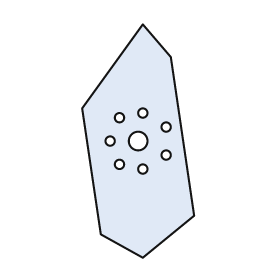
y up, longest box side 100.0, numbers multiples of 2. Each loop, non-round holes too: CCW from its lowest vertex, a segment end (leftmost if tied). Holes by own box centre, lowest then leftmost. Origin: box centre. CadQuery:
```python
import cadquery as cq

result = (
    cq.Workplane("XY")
    .moveTo(2.0, -50.0)
    .lineTo(24.0, -32.0)
    .lineTo(14.0, 36.0)
    .lineTo(2.0, 50.0)
    .lineTo(-24.0, 14.0)
    .lineTo(-16.0, -40.0)
    .close()
    .moveTo(2.0, -12.0)
    .circle(2.0)
    .moveTo(-8.0, -10.0)
    .circle(2.0)
    .moveTo(12.0, -6.0)
    .circle(2.0)
    .moveTo(-12.0, 0.0)
    .circle(2.0)
    .moveTo(0.0, 0.0)
    .circle(4.0)
    .moveTo(12.0, 6.0)
    .circle(2.0)
    .moveTo(-8.0, 10.0)
    .circle(2.0)
    .moveTo(2.0, 12.0)
    .circle(2.0)
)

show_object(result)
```